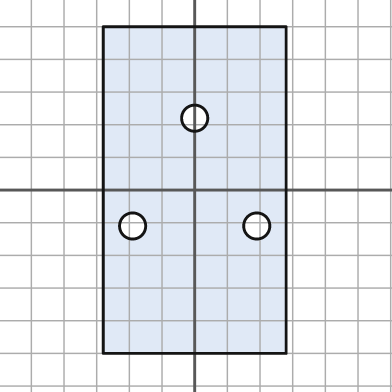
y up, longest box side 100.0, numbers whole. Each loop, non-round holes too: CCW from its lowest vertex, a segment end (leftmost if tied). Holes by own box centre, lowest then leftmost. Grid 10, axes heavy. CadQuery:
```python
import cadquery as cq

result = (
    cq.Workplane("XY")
    .moveTo(-28.0, -50.0)
    .lineTo(28.0, -50.0)
    .lineTo(28.0, 50.0)
    .lineTo(-28.0, 50.0)
    .close()
    .moveTo(-19.0, -11.0)
    .circle(4.0)
    .moveTo(19.0, -11.0)
    .circle(4.0)
    .moveTo(0.0, 22.0)
    .circle(4.0)
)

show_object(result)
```